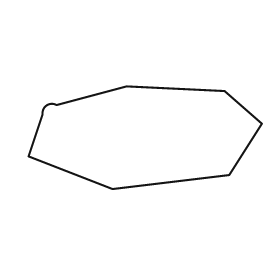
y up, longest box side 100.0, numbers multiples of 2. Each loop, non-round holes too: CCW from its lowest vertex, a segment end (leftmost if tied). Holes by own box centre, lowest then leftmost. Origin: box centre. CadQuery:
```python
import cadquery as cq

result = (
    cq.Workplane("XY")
    .moveTo(-14.0, -22.0)
    .lineTo(36.0, -16.0)
    .lineTo(50.0, 6.0)
    .lineTo(34.0, 20.0)
    .lineTo(-8.0, 22.0)
    .lineTo(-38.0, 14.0)
    .threePointArc((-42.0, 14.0), (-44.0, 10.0))
    .lineTo(-50.0, -8.0)
    .close()
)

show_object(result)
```